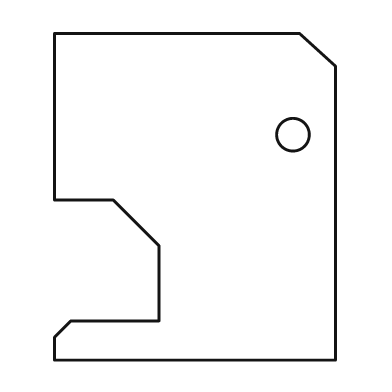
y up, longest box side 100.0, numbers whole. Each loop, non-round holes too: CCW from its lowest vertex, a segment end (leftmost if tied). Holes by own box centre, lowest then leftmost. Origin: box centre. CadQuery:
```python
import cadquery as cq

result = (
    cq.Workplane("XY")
    .moveTo(-43.0, -50.0)
    .lineTo(43.0, -50.0)
    .lineTo(43.0, 40.0)
    .lineTo(32.0, 50.0)
    .lineTo(-43.0, 50.0)
    .lineTo(-43.0, -1.0)
    .lineTo(-25.0, -1.0)
    .lineTo(-11.0, -15.0)
    .lineTo(-11.0, -38.0)
    .lineTo(-38.0, -38.0)
    .lineTo(-43.0, -43.0)
    .close()
    .moveTo(30.0, 19.0)
    .circle(5.0)
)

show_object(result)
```